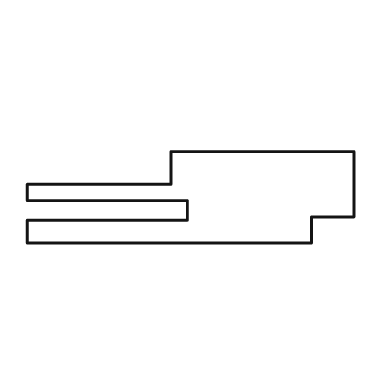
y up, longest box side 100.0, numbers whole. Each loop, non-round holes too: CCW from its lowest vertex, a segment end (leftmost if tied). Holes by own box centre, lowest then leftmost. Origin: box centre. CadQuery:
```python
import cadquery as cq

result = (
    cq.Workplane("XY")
    .moveTo(-50.0, -14.0)
    .lineTo(37.0, -14.0)
    .lineTo(37.0, -6.0)
    .lineTo(50.0, -6.0)
    .lineTo(50.0, 14.0)
    .lineTo(-6.0, 14.0)
    .lineTo(-6.0, 4.0)
    .lineTo(-50.0, 4.0)
    .lineTo(-50.0, -1.0)
    .lineTo(-1.0, -1.0)
    .lineTo(-1.0, -7.0)
    .lineTo(-50.0, -7.0)
    .close()
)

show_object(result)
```